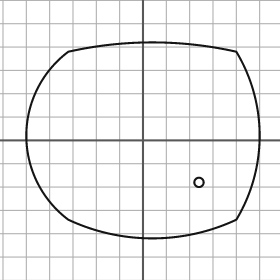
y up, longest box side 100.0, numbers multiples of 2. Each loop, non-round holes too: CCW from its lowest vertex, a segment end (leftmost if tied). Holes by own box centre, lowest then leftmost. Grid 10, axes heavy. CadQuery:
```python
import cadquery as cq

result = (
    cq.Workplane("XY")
    .moveTo(-32.0, -34.0)
    .threePointArc((4.0, -42.0), (40.0, -34.0))
    .threePointArc((50.0, 2.0), (40.0, 38.0))
    .threePointArc((4.0, 42.0), (-32.0, 38.0))
    .threePointArc((-50.0, 2.0), (-32.0, -34.0))
    .close()
    .moveTo(24.0, -18.0)
    .circle(2.0)
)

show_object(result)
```